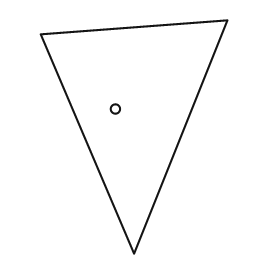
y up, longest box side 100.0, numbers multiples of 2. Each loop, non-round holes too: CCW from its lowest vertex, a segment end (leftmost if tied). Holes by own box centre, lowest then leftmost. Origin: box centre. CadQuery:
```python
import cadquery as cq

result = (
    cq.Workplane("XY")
    .moveTo(0.0, -50.0)
    .lineTo(40.0, 50.0)
    .lineTo(-40.0, 44.0)
    .close()
    .moveTo(-8.0, 12.0)
    .circle(2.0)
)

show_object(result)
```